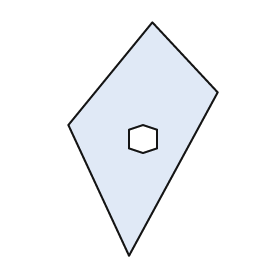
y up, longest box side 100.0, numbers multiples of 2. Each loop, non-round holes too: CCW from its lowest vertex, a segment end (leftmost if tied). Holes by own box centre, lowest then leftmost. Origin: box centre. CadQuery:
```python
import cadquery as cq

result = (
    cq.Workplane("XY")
    .moveTo(-6.0, -50.0)
    .lineTo(32.0, 20.0)
    .lineTo(4.0, 50.0)
    .lineTo(-32.0, 6.0)
    .close()
    .moveTo(0.0, -6.0)
    .lineTo(6.0, -4.0)
    .lineTo(6.0, 4.0)
    .lineTo(0.0, 6.0)
    .lineTo(-6.0, 4.0)
    .lineTo(-6.0, -4.0)
    .close()
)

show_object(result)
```